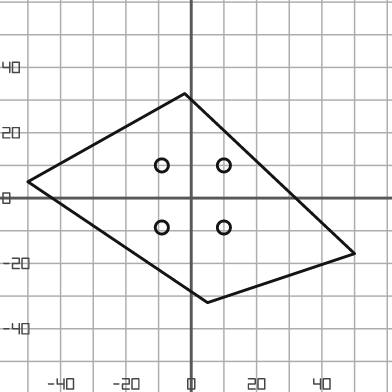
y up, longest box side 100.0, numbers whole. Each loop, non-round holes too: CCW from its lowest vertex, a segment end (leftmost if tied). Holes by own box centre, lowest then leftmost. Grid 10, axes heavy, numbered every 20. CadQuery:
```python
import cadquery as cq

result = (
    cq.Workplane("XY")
    .moveTo(5.0, -32.0)
    .lineTo(50.0, -17.0)
    .lineTo(-2.0, 32.0)
    .lineTo(-50.0, 5.0)
    .close()
    .moveTo(-9.0, -9.0)
    .circle(2.0)
    .moveTo(10.0, -9.0)
    .circle(2.0)
    .moveTo(-9.0, 10.0)
    .circle(2.0)
    .moveTo(10.0, 10.0)
    .circle(2.0)
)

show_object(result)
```